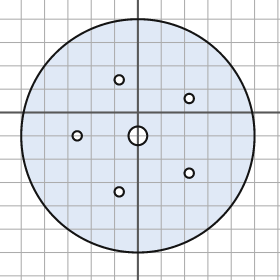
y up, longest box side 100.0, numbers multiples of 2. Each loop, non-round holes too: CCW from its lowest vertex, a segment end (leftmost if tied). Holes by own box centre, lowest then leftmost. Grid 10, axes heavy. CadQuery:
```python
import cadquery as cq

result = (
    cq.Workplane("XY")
    .moveTo(0.0, -10.0)
    .circle(50.0)
    .moveTo(-8.0, -34.0)
    .circle(2.0)
    .moveTo(22.0, -26.0)
    .circle(2.0)
    .moveTo(-26.0, -10.0)
    .circle(2.0)
    .moveTo(0.0, -10.0)
    .circle(4.0)
    .moveTo(22.0, 6.0)
    .circle(2.0)
    .moveTo(-8.0, 14.0)
    .circle(2.0)
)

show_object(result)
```